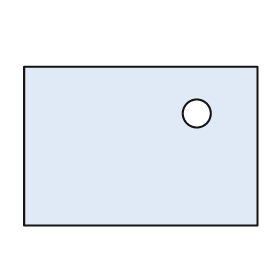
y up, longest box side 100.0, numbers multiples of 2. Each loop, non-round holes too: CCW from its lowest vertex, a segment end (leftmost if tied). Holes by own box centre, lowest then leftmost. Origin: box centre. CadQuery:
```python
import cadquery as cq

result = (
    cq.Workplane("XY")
    .moveTo(-50.0, -34.0)
    .lineTo(50.0, -34.0)
    .lineTo(50.0, 34.0)
    .lineTo(-50.0, 34.0)
    .close()
    .moveTo(24.0, 14.0)
    .circle(6.0)
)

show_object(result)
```